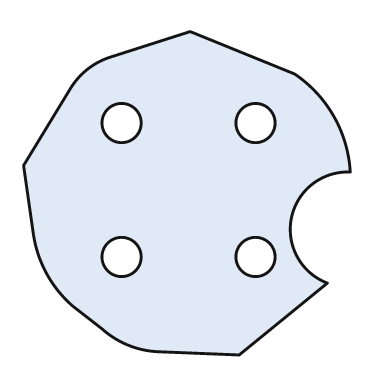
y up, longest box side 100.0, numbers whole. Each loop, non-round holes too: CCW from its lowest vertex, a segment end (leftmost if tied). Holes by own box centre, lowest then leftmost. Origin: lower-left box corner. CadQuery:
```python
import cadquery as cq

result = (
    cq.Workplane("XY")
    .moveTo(66.0, 0.0)
    .lineTo(93.0, 22.0)
    .threePointArc((82.0, 42.0), (100.0, 56.0))
    .threePointArc((95.0, 73.0), (83.0, 86.0))
    .lineTo(51.0, 99.0)
    .lineTo(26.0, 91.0)
    .threePointArc((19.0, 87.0), (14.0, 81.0))
    .lineTo(0.0, 58.0)
    .lineTo(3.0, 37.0)
    .threePointArc((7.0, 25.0), (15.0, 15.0))
    .lineTo(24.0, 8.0)
    .threePointArc((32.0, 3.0), (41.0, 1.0))
    .close()
    .moveTo(30.0, 30.0)
    .circle(6.0)
    .moveTo(71.0, 30.0)
    .circle(6.0)
    .moveTo(30.0, 71.0)
    .circle(6.0)
    .moveTo(71.0, 71.0)
    .circle(6.0)
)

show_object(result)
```